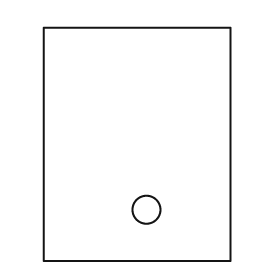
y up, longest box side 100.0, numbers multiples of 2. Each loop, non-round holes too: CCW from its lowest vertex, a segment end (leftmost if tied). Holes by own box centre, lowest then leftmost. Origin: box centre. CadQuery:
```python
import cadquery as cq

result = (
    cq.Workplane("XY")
    .moveTo(-40.0, -50.0)
    .lineTo(40.0, -50.0)
    .lineTo(40.0, 50.0)
    .lineTo(-40.0, 50.0)
    .close()
    .moveTo(4.0, -28.0)
    .circle(6.0)
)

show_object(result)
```